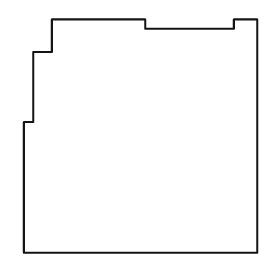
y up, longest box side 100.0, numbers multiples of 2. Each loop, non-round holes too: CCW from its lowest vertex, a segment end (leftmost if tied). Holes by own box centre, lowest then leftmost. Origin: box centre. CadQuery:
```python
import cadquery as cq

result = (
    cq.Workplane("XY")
    .moveTo(-50.0, -50.0)
    .lineTo(50.0, -50.0)
    .lineTo(50.0, 50.0)
    .lineTo(40.0, 50.0)
    .lineTo(40.0, 46.0)
    .lineTo(2.0, 46.0)
    .lineTo(2.0, 50.0)
    .lineTo(-38.0, 50.0)
    .lineTo(-38.0, 36.0)
    .lineTo(-46.0, 36.0)
    .lineTo(-46.0, 6.0)
    .lineTo(-50.0, 6.0)
    .close()
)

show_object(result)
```